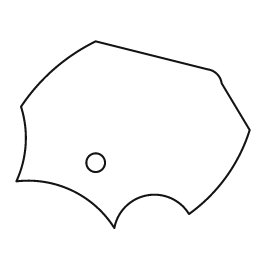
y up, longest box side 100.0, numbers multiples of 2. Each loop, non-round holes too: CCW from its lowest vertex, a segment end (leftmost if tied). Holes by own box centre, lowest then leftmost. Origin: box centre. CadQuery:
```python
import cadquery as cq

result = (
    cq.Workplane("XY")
    .moveTo(-8.0, -40.0)
    .threePointArc((6.0, -26.0), (24.0, -34.0))
    .threePointArc((40.0, -18.0), (50.0, 2.0))
    .lineTo(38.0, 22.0)
    .threePointArc((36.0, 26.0), (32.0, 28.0))
    .lineTo(-16.0, 40.0)
    .threePointArc((-34.0, 28.0), (-48.0, 12.0))
    .threePointArc((-46.0, -4.0), (-50.0, -20.0))
    .threePointArc((-26.0, -24.0), (-8.0, -40.0))
    .close()
    .moveTo(-16.0, -12.0)
    .circle(4.0)
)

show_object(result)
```